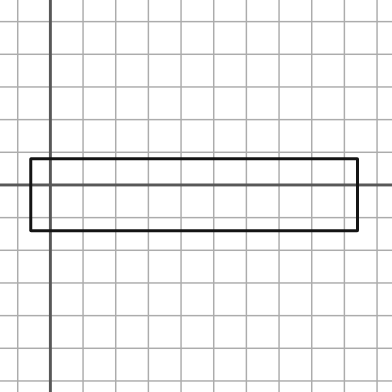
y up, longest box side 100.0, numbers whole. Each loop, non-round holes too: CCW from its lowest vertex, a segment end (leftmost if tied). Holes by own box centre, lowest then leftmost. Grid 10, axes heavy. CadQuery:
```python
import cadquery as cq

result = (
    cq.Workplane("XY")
    .moveTo(-6.0, -14.0)
    .lineTo(94.0, -14.0)
    .lineTo(94.0, 8.0)
    .lineTo(-6.0, 8.0)
    .close()
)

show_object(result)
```